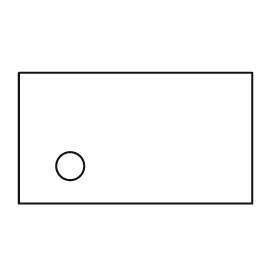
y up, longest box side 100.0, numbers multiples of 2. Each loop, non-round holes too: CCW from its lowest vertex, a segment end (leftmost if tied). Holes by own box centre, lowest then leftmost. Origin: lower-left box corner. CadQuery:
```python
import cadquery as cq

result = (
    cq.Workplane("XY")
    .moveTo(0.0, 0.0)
    .lineTo(100.0, 0.0)
    .lineTo(100.0, 56.0)
    .lineTo(0.0, 56.0)
    .close()
    .moveTo(22.0, 16.0)
    .circle(6.0)
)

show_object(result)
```